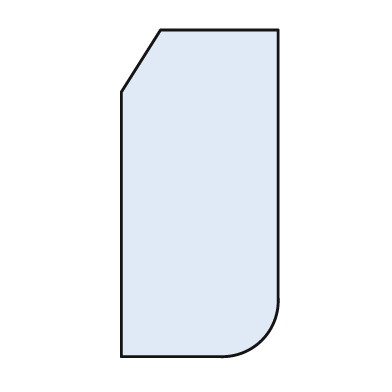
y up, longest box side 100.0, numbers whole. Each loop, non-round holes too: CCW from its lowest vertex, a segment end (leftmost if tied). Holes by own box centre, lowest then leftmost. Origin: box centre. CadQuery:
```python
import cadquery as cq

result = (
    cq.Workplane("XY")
    .moveTo(-24.0, -50.0)
    .lineTo(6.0, -50.0)
    .threePointArc((19.0, -45.0), (24.0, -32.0))
    .lineTo(24.0, 50.0)
    .lineTo(-12.0, 50.0)
    .lineTo(-24.0, 31.0)
    .close()
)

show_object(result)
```